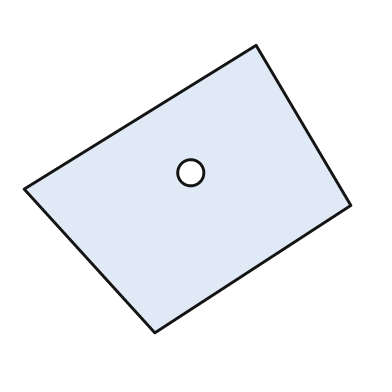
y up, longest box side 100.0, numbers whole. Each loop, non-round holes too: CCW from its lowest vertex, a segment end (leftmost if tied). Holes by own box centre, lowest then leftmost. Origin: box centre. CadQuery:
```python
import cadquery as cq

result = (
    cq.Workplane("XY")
    .moveTo(-10.0, -44.0)
    .lineTo(50.0, -5.0)
    .lineTo(21.0, 44.0)
    .lineTo(-50.0, 0.0)
    .close()
    .moveTo(1.0, 5.0)
    .circle(4.0)
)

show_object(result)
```